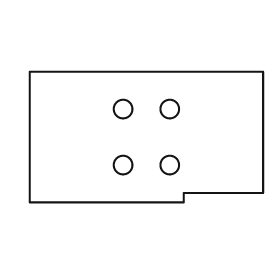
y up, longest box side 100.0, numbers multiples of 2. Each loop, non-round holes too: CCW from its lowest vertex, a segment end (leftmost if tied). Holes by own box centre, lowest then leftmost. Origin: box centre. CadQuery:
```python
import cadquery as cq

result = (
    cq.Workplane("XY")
    .moveTo(-50.0, -28.0)
    .lineTo(16.0, -28.0)
    .lineTo(16.0, -24.0)
    .lineTo(50.0, -24.0)
    .lineTo(50.0, 28.0)
    .lineTo(-50.0, 28.0)
    .close()
    .moveTo(-10.0, -12.0)
    .circle(4.0)
    .moveTo(10.0, -12.0)
    .circle(4.0)
    .moveTo(-10.0, 12.0)
    .circle(4.0)
    .moveTo(10.0, 12.0)
    .circle(4.0)
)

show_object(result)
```